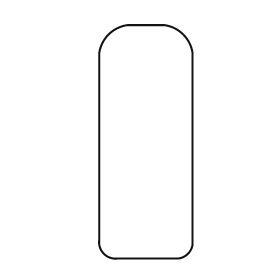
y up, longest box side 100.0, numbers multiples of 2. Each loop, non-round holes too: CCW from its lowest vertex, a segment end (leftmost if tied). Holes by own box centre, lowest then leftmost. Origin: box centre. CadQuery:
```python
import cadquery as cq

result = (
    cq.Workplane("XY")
    .moveTo(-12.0, -50.0)
    .lineTo(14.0, -50.0)
    .threePointArc((18.0, -48.0), (20.0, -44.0))
    .lineTo(20.0, 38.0)
    .threePointArc((16.0, 46.0), (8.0, 50.0))
    .lineTo(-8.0, 50.0)
    .threePointArc((-16.0, 46.0), (-20.0, 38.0))
    .lineTo(-20.0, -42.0)
    .threePointArc((-18.0, -48.0), (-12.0, -50.0))
    .close()
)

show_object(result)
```